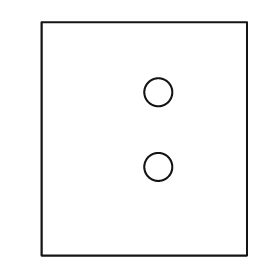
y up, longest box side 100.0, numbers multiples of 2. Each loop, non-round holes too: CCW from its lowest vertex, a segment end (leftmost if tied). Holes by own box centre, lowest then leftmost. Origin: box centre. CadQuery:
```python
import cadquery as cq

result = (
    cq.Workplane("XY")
    .moveTo(-44.0, -50.0)
    .lineTo(44.0, -50.0)
    .lineTo(44.0, 50.0)
    .lineTo(-44.0, 50.0)
    .close()
    .moveTo(6.0, -12.0)
    .circle(6.0)
    .moveTo(6.0, 20.0)
    .circle(6.0)
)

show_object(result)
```